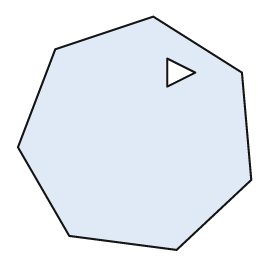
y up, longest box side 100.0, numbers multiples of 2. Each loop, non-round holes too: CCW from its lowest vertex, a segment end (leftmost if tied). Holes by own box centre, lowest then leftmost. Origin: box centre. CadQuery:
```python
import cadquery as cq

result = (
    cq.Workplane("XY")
    .moveTo(18.0, -50.0)
    .lineTo(50.0, -20.0)
    .lineTo(46.0, 26.0)
    .lineTo(8.0, 50.0)
    .lineTo(-34.0, 36.0)
    .lineTo(-50.0, -6.0)
    .lineTo(-28.0, -44.0)
    .close()
    .moveTo(14.0, 20.0)
    .lineTo(26.0, 26.0)
    .lineTo(14.0, 32.0)
    .close()
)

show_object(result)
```